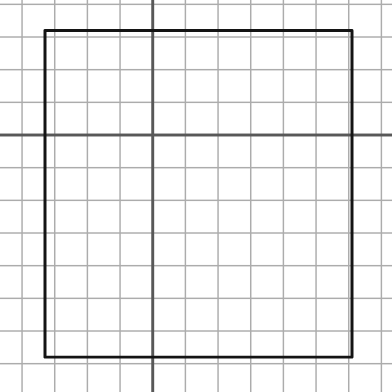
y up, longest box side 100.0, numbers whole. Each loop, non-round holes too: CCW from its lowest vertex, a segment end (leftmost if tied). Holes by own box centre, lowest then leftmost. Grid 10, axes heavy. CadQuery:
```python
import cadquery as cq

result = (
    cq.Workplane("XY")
    .moveTo(-33.0, -68.0)
    .lineTo(61.0, -68.0)
    .lineTo(61.0, 32.0)
    .lineTo(-33.0, 32.0)
    .close()
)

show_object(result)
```